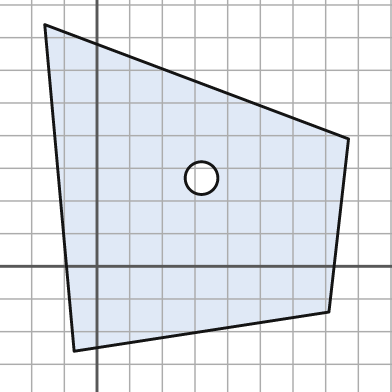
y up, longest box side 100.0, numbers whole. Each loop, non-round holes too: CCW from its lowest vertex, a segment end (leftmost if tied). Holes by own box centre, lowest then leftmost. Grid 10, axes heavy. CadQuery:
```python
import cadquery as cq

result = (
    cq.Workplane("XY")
    .moveTo(-7.0, -26.0)
    .lineTo(71.0, -14.0)
    .lineTo(77.0, 39.0)
    .lineTo(-16.0, 74.0)
    .close()
    .moveTo(32.0, 27.0)
    .circle(5.0)
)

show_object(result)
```